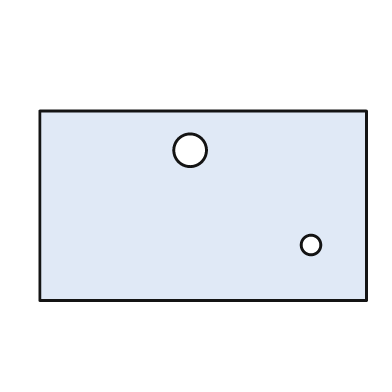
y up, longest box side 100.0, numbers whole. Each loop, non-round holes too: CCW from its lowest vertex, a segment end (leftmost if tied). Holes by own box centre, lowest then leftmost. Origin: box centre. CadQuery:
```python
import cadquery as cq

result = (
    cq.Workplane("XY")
    .moveTo(-50.0, -29.0)
    .lineTo(50.0, -29.0)
    .lineTo(50.0, 29.0)
    .lineTo(-50.0, 29.0)
    .close()
    .moveTo(33.0, -12.0)
    .circle(3.0)
    .moveTo(-4.0, 17.0)
    .circle(5.0)
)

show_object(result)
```